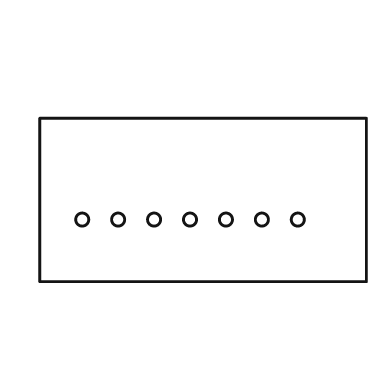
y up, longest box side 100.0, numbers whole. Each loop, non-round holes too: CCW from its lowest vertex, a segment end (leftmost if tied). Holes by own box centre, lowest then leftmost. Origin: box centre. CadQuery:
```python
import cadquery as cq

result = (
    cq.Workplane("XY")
    .moveTo(-50.0, -25.0)
    .lineTo(50.0, -25.0)
    .lineTo(50.0, 25.0)
    .lineTo(-50.0, 25.0)
    .close()
    .moveTo(-37.0, -6.0)
    .circle(2.0)
    .moveTo(-26.0, -6.0)
    .circle(2.0)
    .moveTo(-15.0, -6.0)
    .circle(2.0)
    .moveTo(-4.0, -6.0)
    .circle(2.0)
    .moveTo(7.0, -6.0)
    .circle(2.0)
    .moveTo(18.0, -6.0)
    .circle(2.0)
    .moveTo(29.0, -6.0)
    .circle(2.0)
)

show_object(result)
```